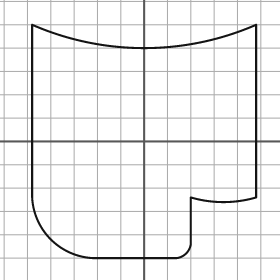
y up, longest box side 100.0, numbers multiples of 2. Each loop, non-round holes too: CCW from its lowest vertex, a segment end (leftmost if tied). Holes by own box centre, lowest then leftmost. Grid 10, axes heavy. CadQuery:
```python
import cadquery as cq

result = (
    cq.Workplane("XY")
    .moveTo(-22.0, -50.0)
    .lineTo(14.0, -50.0)
    .threePointArc((18.0, -48.0), (20.0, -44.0))
    .lineTo(20.0, -24.0)
    .threePointArc((34.0, -26.0), (48.0, -24.0))
    .lineTo(48.0, 50.0)
    .threePointArc((0.0, 40.0), (-48.0, 50.0))
    .lineTo(-48.0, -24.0)
    .threePointArc((-40.0, -42.0), (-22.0, -50.0))
    .close()
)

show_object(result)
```